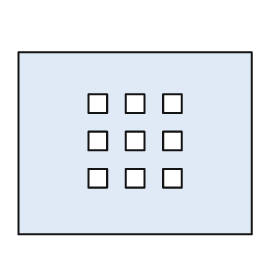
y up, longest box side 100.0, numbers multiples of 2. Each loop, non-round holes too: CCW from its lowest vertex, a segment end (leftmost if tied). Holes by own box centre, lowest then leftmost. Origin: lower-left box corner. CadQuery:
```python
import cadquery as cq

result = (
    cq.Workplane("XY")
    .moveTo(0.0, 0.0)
    .lineTo(100.0, 0.0)
    .lineTo(100.0, 78.0)
    .lineTo(0.0, 78.0)
    .close()
    .moveTo(30.0, 20.0)
    .lineTo(38.0, 20.0)
    .lineTo(38.0, 28.0)
    .lineTo(30.0, 28.0)
    .close()
    .moveTo(46.0, 20.0)
    .lineTo(54.0, 20.0)
    .lineTo(54.0, 28.0)
    .lineTo(46.0, 28.0)
    .close()
    .moveTo(62.0, 20.0)
    .lineTo(70.0, 20.0)
    .lineTo(70.0, 28.0)
    .lineTo(62.0, 28.0)
    .close()
    .moveTo(30.0, 36.0)
    .lineTo(38.0, 36.0)
    .lineTo(38.0, 44.0)
    .lineTo(30.0, 44.0)
    .close()
    .moveTo(46.0, 36.0)
    .lineTo(54.0, 36.0)
    .lineTo(54.0, 44.0)
    .lineTo(46.0, 44.0)
    .close()
    .moveTo(62.0, 36.0)
    .lineTo(70.0, 36.0)
    .lineTo(70.0, 44.0)
    .lineTo(62.0, 44.0)
    .close()
    .moveTo(30.0, 52.0)
    .lineTo(38.0, 52.0)
    .lineTo(38.0, 60.0)
    .lineTo(30.0, 60.0)
    .close()
    .moveTo(46.0, 52.0)
    .lineTo(54.0, 52.0)
    .lineTo(54.0, 60.0)
    .lineTo(46.0, 60.0)
    .close()
    .moveTo(62.0, 52.0)
    .lineTo(70.0, 52.0)
    .lineTo(70.0, 60.0)
    .lineTo(62.0, 60.0)
    .close()
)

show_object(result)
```